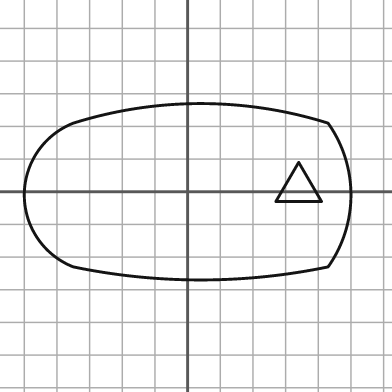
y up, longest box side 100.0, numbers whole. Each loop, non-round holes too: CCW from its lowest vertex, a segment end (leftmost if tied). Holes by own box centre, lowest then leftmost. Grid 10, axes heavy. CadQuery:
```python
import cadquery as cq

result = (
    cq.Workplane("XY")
    .moveTo(-35.0, -23.0)
    .threePointArc((4.0, -27.0), (43.0, -23.0))
    .threePointArc((50.0, -1.0), (43.0, 21.0))
    .threePointArc((4.0, 27.0), (-35.0, 21.0))
    .threePointArc((-50.0, -1.0), (-35.0, -23.0))
    .close()
    .moveTo(27.0, -3.0)
    .lineTo(41.0, -3.0)
    .lineTo(34.0, 9.0)
    .close()
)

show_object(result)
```